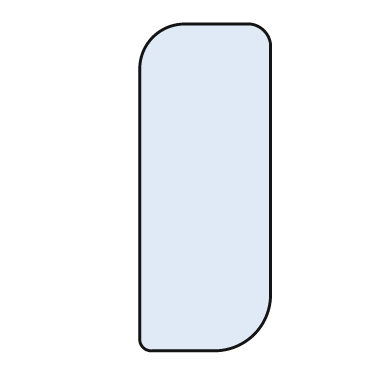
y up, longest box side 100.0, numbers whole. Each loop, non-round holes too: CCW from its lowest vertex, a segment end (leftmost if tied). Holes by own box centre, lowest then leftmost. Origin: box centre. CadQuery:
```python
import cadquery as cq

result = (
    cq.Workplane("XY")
    .moveTo(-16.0, -50.0)
    .lineTo(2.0, -50.0)
    .threePointArc((15.0, -45.0), (20.0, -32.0))
    .lineTo(20.0, 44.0)
    .threePointArc((18.0, 48.0), (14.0, 50.0))
    .lineTo(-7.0, 50.0)
    .threePointArc((-16.0, 46.0), (-20.0, 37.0))
    .lineTo(-20.0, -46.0)
    .threePointArc((-19.0, -49.0), (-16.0, -50.0))
    .close()
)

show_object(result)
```